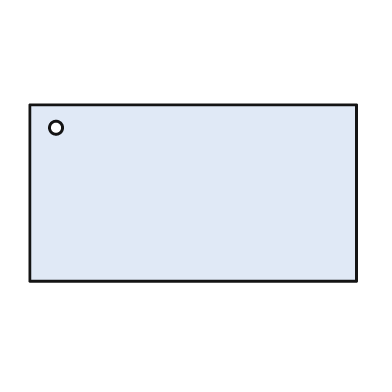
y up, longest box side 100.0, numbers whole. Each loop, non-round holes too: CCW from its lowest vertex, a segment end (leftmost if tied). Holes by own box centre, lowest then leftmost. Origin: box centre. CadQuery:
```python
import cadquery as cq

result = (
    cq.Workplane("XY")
    .moveTo(-50.0, -27.0)
    .lineTo(50.0, -27.0)
    .lineTo(50.0, 27.0)
    .lineTo(-50.0, 27.0)
    .close()
    .moveTo(-42.0, 20.0)
    .circle(2.0)
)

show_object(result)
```